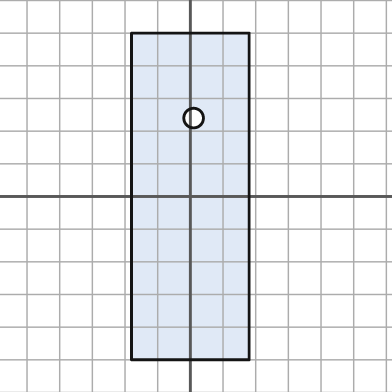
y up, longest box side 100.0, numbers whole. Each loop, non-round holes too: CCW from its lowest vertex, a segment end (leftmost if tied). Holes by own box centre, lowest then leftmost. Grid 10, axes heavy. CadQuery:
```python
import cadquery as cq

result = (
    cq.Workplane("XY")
    .moveTo(-18.0, -50.0)
    .lineTo(18.0, -50.0)
    .lineTo(18.0, 50.0)
    .lineTo(-18.0, 50.0)
    .close()
    .moveTo(1.0, 24.0)
    .circle(3.0)
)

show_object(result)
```